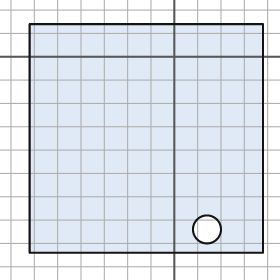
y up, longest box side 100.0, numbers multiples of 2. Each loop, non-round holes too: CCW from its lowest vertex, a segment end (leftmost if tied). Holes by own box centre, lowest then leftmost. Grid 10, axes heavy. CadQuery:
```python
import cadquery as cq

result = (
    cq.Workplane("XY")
    .moveTo(-62.0, -84.0)
    .lineTo(38.0, -84.0)
    .lineTo(38.0, 14.0)
    .lineTo(-62.0, 14.0)
    .close()
    .moveTo(14.0, -74.0)
    .circle(6.0)
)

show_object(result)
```